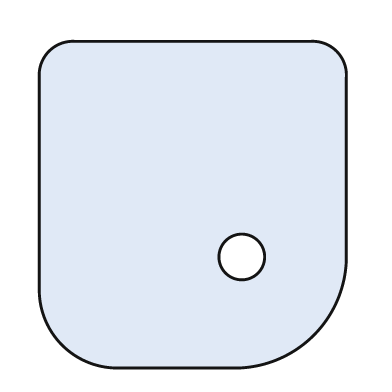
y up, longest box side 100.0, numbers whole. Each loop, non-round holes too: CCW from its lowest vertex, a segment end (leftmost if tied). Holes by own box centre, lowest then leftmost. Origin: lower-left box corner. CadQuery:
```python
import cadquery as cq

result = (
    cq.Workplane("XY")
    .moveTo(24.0, 0.0)
    .lineTo(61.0, 0.0)
    .threePointArc((84.0, 10.0), (94.0, 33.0))
    .lineTo(94.0, 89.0)
    .threePointArc((91.0, 97.0), (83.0, 100.0))
    .lineTo(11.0, 100.0)
    .threePointArc((3.0, 97.0), (0.0, 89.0))
    .lineTo(0.0, 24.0)
    .threePointArc((7.0, 7.0), (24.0, 0.0))
    .close()
    .moveTo(62.0, 34.0)
    .circle(7.0)
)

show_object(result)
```